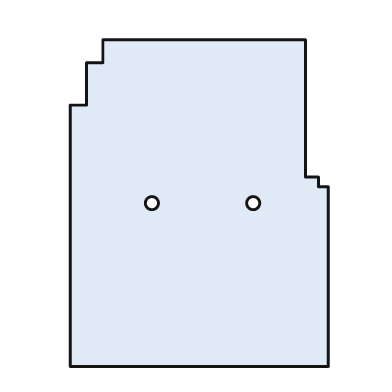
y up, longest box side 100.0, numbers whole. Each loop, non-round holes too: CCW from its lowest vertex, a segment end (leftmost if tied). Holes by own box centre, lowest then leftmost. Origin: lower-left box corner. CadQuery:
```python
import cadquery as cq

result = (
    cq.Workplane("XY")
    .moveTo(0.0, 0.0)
    .lineTo(79.0, 0.0)
    .lineTo(79.0, 55.0)
    .lineTo(76.0, 55.0)
    .lineTo(76.0, 58.0)
    .lineTo(72.0, 58.0)
    .lineTo(72.0, 100.0)
    .lineTo(10.0, 100.0)
    .lineTo(10.0, 93.0)
    .lineTo(5.0, 93.0)
    .lineTo(5.0, 80.0)
    .lineTo(0.0, 80.0)
    .close()
    .moveTo(25.0, 50.0)
    .circle(2.0)
    .moveTo(56.0, 50.0)
    .circle(2.0)
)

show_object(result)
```